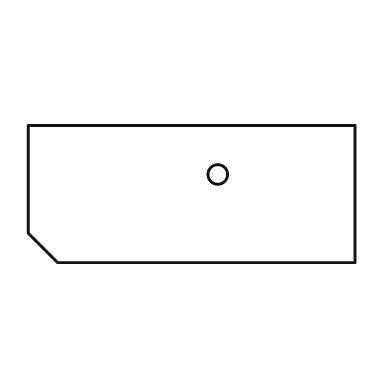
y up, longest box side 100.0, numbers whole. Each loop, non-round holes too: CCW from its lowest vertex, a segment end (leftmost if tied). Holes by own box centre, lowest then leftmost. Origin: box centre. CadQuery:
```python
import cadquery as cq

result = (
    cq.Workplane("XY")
    .moveTo(-41.0, -21.0)
    .lineTo(50.0, -21.0)
    .lineTo(50.0, 21.0)
    .lineTo(-50.0, 21.0)
    .lineTo(-50.0, -12.0)
    .close()
    .moveTo(8.0, 6.0)
    .circle(3.0)
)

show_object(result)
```